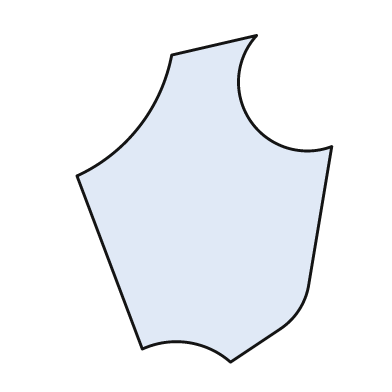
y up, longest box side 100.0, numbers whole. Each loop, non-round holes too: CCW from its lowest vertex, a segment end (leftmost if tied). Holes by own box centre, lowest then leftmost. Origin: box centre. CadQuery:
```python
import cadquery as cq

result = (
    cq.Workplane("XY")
    .moveTo(8.0, -50.0)
    .lineTo(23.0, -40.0)
    .threePointArc((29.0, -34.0), (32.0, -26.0))
    .lineTo(39.0, 16.0)
    .threePointArc((14.0, 24.0), (16.0, 50.0))
    .lineTo(-10.0, 44.0)
    .threePointArc((-20.0, 22.0), (-39.0, 7.0))
    .lineTo(-19.0, -46.0)
    .threePointArc((-5.0, -44.0), (8.0, -50.0))
    .close()
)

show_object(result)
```